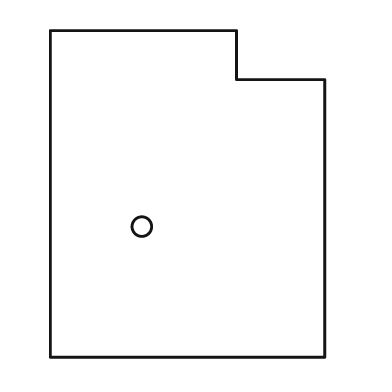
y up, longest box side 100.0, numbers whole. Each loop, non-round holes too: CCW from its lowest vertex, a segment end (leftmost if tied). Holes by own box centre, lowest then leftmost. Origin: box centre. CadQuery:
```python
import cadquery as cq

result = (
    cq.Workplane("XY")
    .moveTo(-42.0, -50.0)
    .lineTo(42.0, -50.0)
    .lineTo(42.0, 35.0)
    .lineTo(15.0, 35.0)
    .lineTo(15.0, 50.0)
    .lineTo(-42.0, 50.0)
    .close()
    .moveTo(-14.0, -10.0)
    .circle(3.0)
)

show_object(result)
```